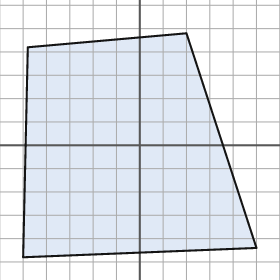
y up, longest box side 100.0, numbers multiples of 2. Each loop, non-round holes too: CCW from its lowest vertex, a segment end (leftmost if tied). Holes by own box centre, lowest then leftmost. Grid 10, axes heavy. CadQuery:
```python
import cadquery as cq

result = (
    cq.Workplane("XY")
    .moveTo(-50.0, -48.0)
    .lineTo(50.0, -44.0)
    .lineTo(20.0, 48.0)
    .lineTo(-48.0, 42.0)
    .close()
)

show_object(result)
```